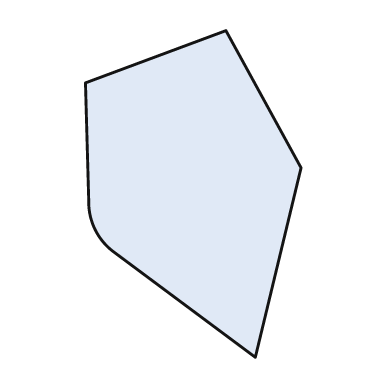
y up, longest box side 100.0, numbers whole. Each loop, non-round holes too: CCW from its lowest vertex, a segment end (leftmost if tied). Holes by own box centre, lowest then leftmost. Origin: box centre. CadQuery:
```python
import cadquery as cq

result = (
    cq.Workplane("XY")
    .moveTo(19.0, -50.0)
    .lineTo(33.0, 8.0)
    .lineTo(10.0, 50.0)
    .lineTo(-33.0, 34.0)
    .lineTo(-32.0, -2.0)
    .threePointArc((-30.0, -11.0), (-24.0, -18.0))
    .close()
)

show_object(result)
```